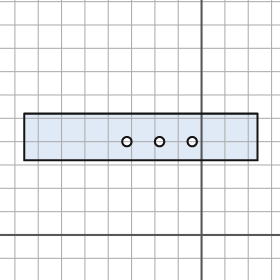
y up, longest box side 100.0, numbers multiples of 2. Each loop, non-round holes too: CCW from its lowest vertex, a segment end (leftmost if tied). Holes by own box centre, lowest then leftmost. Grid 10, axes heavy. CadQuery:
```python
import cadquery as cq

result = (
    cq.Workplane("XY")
    .moveTo(-76.0, 32.0)
    .lineTo(24.0, 32.0)
    .lineTo(24.0, 52.0)
    .lineTo(-76.0, 52.0)
    .close()
    .moveTo(-32.0, 40.0)
    .circle(2.0)
    .moveTo(-18.0, 40.0)
    .circle(2.0)
    .moveTo(-4.0, 40.0)
    .circle(2.0)
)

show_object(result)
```